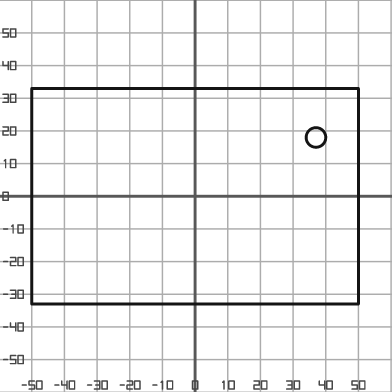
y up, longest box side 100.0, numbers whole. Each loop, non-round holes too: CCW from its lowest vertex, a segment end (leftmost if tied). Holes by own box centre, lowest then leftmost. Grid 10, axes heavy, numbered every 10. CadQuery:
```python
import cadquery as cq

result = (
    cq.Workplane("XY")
    .moveTo(-50.0, -33.0)
    .lineTo(50.0, -33.0)
    .lineTo(50.0, 33.0)
    .lineTo(-50.0, 33.0)
    .close()
    .moveTo(37.0, 18.0)
    .circle(3.0)
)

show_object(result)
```